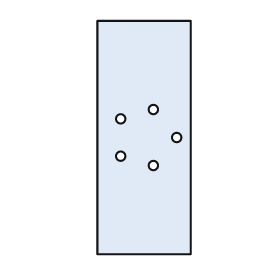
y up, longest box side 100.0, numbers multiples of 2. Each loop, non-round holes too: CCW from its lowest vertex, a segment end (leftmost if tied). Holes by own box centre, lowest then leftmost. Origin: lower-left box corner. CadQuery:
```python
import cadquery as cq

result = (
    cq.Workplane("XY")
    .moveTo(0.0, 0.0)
    .lineTo(40.0, 0.0)
    .lineTo(40.0, 100.0)
    .lineTo(0.0, 100.0)
    .close()
    .moveTo(24.0, 38.0)
    .circle(2.0)
    .moveTo(10.0, 42.0)
    .circle(2.0)
    .moveTo(34.0, 50.0)
    .circle(2.0)
    .moveTo(10.0, 58.0)
    .circle(2.0)
    .moveTo(24.0, 62.0)
    .circle(2.0)
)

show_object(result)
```